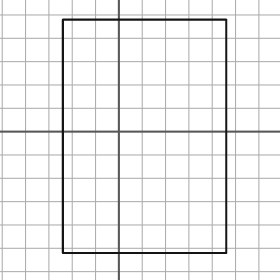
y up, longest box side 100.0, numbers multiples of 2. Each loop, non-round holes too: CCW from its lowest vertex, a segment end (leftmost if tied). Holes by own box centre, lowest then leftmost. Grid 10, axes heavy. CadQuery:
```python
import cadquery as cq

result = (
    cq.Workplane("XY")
    .moveTo(-24.0, -52.0)
    .lineTo(46.0, -52.0)
    .lineTo(46.0, 48.0)
    .lineTo(-24.0, 48.0)
    .close()
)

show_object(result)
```